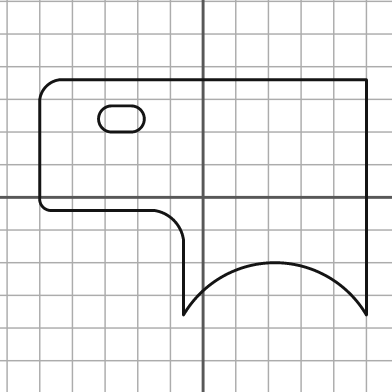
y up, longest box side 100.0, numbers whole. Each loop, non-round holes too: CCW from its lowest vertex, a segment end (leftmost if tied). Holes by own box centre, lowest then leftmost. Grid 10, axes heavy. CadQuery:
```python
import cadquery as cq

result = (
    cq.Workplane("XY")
    .moveTo(-6.0, -36.0)
    .threePointArc((22.0, -20.0), (50.0, -36.0))
    .lineTo(50.0, 36.0)
    .lineTo(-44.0, 36.0)
    .threePointArc((-48.0, 34.0), (-50.0, 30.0))
    .lineTo(-50.0, 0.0)
    .threePointArc((-49.0, -3.0), (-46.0, -4.0))
    .lineTo(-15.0, -4.0)
    .threePointArc((-9.0, -7.0), (-6.0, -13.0))
    .close()
    .moveTo(-28.0, 20.0)
    .lineTo(-22.0, 20.0)
    .threePointArc((-18.0, 24.0), (-22.0, 28.0))
    .lineTo(-28.0, 28.0)
    .threePointArc((-32.0, 24.0), (-28.0, 20.0))
    .close()
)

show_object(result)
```